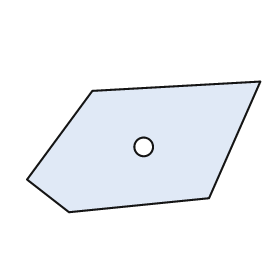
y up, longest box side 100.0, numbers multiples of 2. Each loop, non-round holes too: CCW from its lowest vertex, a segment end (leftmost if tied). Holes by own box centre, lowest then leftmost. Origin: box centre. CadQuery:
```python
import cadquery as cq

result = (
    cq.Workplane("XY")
    .moveTo(-32.0, -28.0)
    .lineTo(28.0, -22.0)
    .lineTo(50.0, 28.0)
    .lineTo(-22.0, 24.0)
    .lineTo(-50.0, -14.0)
    .close()
    .moveTo(0.0, 0.0)
    .circle(4.0)
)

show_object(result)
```